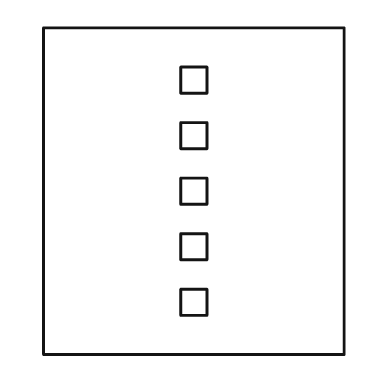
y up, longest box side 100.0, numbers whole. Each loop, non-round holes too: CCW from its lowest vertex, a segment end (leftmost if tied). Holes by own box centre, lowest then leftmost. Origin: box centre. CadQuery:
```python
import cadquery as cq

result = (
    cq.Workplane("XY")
    .moveTo(-46.0, -50.0)
    .lineTo(46.0, -50.0)
    .lineTo(46.0, 50.0)
    .lineTo(-46.0, 50.0)
    .close()
    .moveTo(-4.0, -38.0)
    .lineTo(4.0, -38.0)
    .lineTo(4.0, -30.0)
    .lineTo(-4.0, -30.0)
    .close()
    .moveTo(-4.0, -21.0)
    .lineTo(4.0, -21.0)
    .lineTo(4.0, -13.0)
    .lineTo(-4.0, -13.0)
    .close()
    .moveTo(-4.0, -4.0)
    .lineTo(4.0, -4.0)
    .lineTo(4.0, 4.0)
    .lineTo(-4.0, 4.0)
    .close()
    .moveTo(-4.0, 13.0)
    .lineTo(4.0, 13.0)
    .lineTo(4.0, 21.0)
    .lineTo(-4.0, 21.0)
    .close()
    .moveTo(-4.0, 30.0)
    .lineTo(4.0, 30.0)
    .lineTo(4.0, 38.0)
    .lineTo(-4.0, 38.0)
    .close()
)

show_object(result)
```